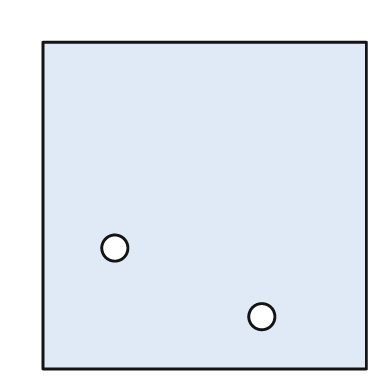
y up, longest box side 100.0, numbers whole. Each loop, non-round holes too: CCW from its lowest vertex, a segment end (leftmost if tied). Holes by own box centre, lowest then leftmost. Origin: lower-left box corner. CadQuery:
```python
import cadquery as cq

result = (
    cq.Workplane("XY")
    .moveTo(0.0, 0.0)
    .lineTo(99.0, 0.0)
    .lineTo(99.0, 100.0)
    .lineTo(0.0, 100.0)
    .close()
    .moveTo(67.0, 16.0)
    .circle(4.0)
    .moveTo(22.0, 37.0)
    .circle(4.0)
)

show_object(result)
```